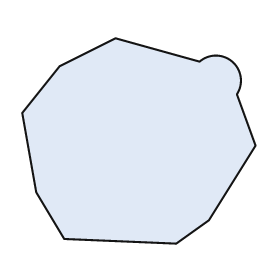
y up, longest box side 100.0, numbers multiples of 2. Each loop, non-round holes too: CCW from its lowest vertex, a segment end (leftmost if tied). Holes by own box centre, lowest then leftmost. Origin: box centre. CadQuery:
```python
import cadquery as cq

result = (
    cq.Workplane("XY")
    .moveTo(16.0, -44.0)
    .lineTo(30.0, -34.0)
    .lineTo(50.0, -2.0)
    .lineTo(42.0, 20.0)
    .threePointArc((40.0, 34.0), (26.0, 34.0))
    .lineTo(-10.0, 44.0)
    .lineTo(-34.0, 32.0)
    .lineTo(-50.0, 12.0)
    .lineTo(-44.0, -22.0)
    .lineTo(-32.0, -42.0)
    .close()
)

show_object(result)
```